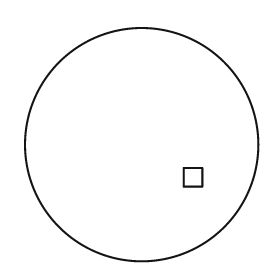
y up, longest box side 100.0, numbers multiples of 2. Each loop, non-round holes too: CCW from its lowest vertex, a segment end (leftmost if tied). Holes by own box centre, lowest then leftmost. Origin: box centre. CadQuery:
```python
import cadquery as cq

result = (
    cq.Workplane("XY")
    .moveTo(0.0, 0.0)
    .circle(50.0)
    .moveTo(18.0, -18.0)
    .lineTo(26.0, -18.0)
    .lineTo(26.0, -10.0)
    .lineTo(18.0, -10.0)
    .close()
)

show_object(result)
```